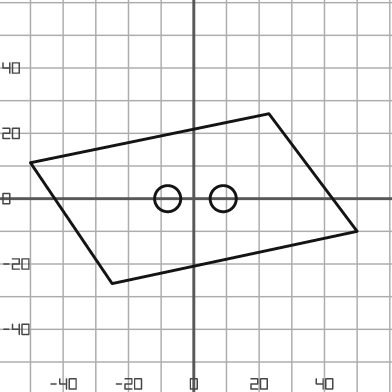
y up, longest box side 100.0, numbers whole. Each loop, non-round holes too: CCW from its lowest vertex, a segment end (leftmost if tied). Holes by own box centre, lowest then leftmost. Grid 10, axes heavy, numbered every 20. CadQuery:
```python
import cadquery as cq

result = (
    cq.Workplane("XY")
    .moveTo(-25.0, -26.0)
    .lineTo(50.0, -10.0)
    .lineTo(23.0, 26.0)
    .lineTo(-50.0, 11.0)
    .close()
    .moveTo(-8.0, 0.0)
    .circle(4.0)
    .moveTo(9.0, 0.0)
    .circle(4.0)
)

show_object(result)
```